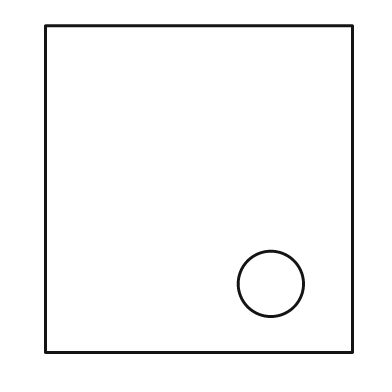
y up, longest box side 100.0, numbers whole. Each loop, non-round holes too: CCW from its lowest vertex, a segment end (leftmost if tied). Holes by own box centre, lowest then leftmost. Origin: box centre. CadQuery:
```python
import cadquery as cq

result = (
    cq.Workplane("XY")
    .moveTo(-47.0, -50.0)
    .lineTo(47.0, -50.0)
    .lineTo(47.0, 50.0)
    .lineTo(-47.0, 50.0)
    .close()
    .moveTo(22.0, -29.0)
    .circle(10.0)
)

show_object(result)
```